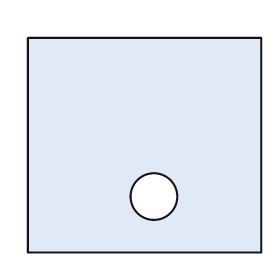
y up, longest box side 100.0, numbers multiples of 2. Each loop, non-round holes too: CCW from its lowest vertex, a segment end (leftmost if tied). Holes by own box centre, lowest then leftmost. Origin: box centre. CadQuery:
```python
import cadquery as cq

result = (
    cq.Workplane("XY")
    .moveTo(-50.0, -46.0)
    .lineTo(50.0, -46.0)
    .lineTo(50.0, 46.0)
    .lineTo(-50.0, 46.0)
    .close()
    .moveTo(4.0, -22.0)
    .circle(10.0)
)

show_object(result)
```